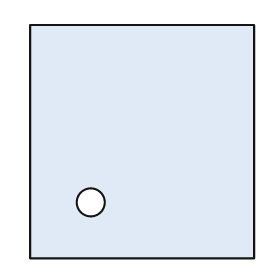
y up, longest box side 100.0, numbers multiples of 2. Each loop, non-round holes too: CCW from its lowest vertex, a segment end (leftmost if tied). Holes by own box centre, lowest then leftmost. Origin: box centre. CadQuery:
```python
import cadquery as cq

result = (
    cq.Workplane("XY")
    .moveTo(-48.0, -50.0)
    .lineTo(48.0, -50.0)
    .lineTo(48.0, 50.0)
    .lineTo(-48.0, 50.0)
    .close()
    .moveTo(-22.0, -26.0)
    .circle(6.0)
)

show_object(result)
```